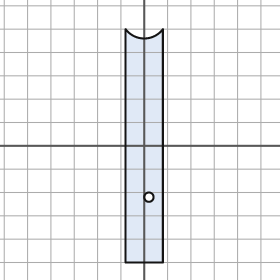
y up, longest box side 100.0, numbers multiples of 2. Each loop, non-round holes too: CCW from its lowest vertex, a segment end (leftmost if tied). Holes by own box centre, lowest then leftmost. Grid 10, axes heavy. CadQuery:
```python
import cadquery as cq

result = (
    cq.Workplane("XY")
    .moveTo(-8.0, -50.0)
    .lineTo(8.0, -50.0)
    .lineTo(8.0, 50.0)
    .threePointArc((0.0, 46.0), (-8.0, 50.0))
    .close()
    .moveTo(2.0, -22.0)
    .circle(2.0)
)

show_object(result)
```